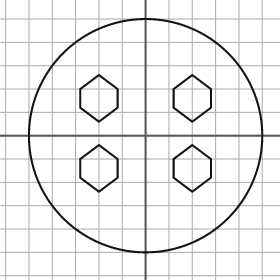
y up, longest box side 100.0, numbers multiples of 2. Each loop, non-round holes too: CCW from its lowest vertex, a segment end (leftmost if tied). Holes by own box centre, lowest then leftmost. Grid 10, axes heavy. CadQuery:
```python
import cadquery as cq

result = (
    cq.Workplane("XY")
    .moveTo(0.0, 0.0)
    .circle(50.0)
    .moveTo(-20.0, -24.0)
    .lineTo(-12.0, -18.0)
    .lineTo(-12.0, -10.0)
    .lineTo(-20.0, -4.0)
    .lineTo(-28.0, -10.0)
    .lineTo(-28.0, -18.0)
    .close()
    .moveTo(20.0, -24.0)
    .lineTo(28.0, -18.0)
    .lineTo(28.0, -10.0)
    .lineTo(20.0, -4.0)
    .lineTo(12.0, -10.0)
    .lineTo(12.0, -18.0)
    .close()
    .moveTo(-20.0, 6.0)
    .lineTo(-12.0, 12.0)
    .lineTo(-12.0, 20.0)
    .lineTo(-20.0, 26.0)
    .lineTo(-28.0, 20.0)
    .lineTo(-28.0, 12.0)
    .close()
    .moveTo(20.0, 6.0)
    .lineTo(28.0, 12.0)
    .lineTo(28.0, 20.0)
    .lineTo(20.0, 26.0)
    .lineTo(12.0, 20.0)
    .lineTo(12.0, 12.0)
    .close()
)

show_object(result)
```